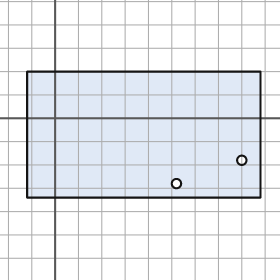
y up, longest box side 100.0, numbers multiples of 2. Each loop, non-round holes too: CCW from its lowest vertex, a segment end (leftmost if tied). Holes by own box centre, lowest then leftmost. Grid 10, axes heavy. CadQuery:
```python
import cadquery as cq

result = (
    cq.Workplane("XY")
    .moveTo(-12.0, -34.0)
    .lineTo(88.0, -34.0)
    .lineTo(88.0, 20.0)
    .lineTo(-12.0, 20.0)
    .close()
    .moveTo(52.0, -28.0)
    .circle(2.0)
    .moveTo(80.0, -18.0)
    .circle(2.0)
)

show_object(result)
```